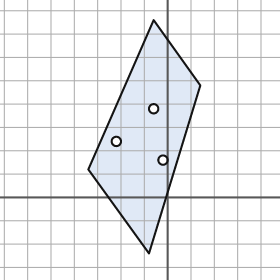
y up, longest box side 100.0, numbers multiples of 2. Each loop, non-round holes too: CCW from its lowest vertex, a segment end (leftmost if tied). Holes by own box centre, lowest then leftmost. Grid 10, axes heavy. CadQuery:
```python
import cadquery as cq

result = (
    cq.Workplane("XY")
    .moveTo(-8.0, -24.0)
    .lineTo(14.0, 48.0)
    .lineTo(-6.0, 76.0)
    .lineTo(-34.0, 12.0)
    .close()
    .moveTo(-2.0, 16.0)
    .circle(2.0)
    .moveTo(-22.0, 24.0)
    .circle(2.0)
    .moveTo(-6.0, 38.0)
    .circle(2.0)
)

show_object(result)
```